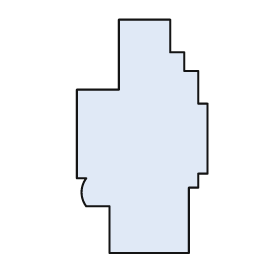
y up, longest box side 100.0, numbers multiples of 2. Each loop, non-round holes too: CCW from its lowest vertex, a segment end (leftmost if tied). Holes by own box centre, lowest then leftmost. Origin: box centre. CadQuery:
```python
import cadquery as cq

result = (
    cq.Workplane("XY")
    .moveTo(-14.0, -50.0)
    .lineTo(20.0, -50.0)
    .lineTo(20.0, -22.0)
    .lineTo(24.0, -22.0)
    .lineTo(24.0, -16.0)
    .lineTo(28.0, -16.0)
    .lineTo(28.0, 14.0)
    .lineTo(24.0, 14.0)
    .lineTo(24.0, 28.0)
    .lineTo(18.0, 28.0)
    .lineTo(18.0, 36.0)
    .lineTo(12.0, 36.0)
    .lineTo(12.0, 50.0)
    .lineTo(-10.0, 50.0)
    .lineTo(-10.0, 20.0)
    .lineTo(-28.0, 20.0)
    .lineTo(-28.0, -18.0)
    .lineTo(-24.0, -18.0)
    .threePointArc((-26.0, -24.0), (-24.0, -30.0))
    .lineTo(-14.0, -30.0)
    .close()
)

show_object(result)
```